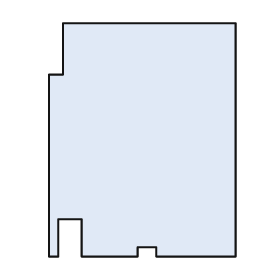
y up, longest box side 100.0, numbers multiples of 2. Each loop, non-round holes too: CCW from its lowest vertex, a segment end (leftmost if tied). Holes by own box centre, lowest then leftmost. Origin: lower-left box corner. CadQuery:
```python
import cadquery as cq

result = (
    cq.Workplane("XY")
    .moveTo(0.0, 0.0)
    .lineTo(4.0, 0.0)
    .lineTo(4.0, 16.0)
    .lineTo(14.0, 16.0)
    .lineTo(14.0, 0.0)
    .lineTo(38.0, 0.0)
    .lineTo(38.0, 4.0)
    .lineTo(46.0, 4.0)
    .lineTo(46.0, 0.0)
    .lineTo(80.0, 0.0)
    .lineTo(80.0, 100.0)
    .lineTo(6.0, 100.0)
    .lineTo(6.0, 78.0)
    .lineTo(0.0, 78.0)
    .close()
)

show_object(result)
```